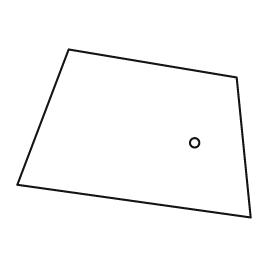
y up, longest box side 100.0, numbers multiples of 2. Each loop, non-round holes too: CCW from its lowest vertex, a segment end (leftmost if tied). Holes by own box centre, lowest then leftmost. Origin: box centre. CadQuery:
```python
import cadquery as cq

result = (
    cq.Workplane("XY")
    .moveTo(50.0, -36.0)
    .lineTo(44.0, 24.0)
    .lineTo(-28.0, 36.0)
    .lineTo(-50.0, -22.0)
    .close()
    .moveTo(26.0, -4.0)
    .circle(2.0)
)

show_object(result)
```